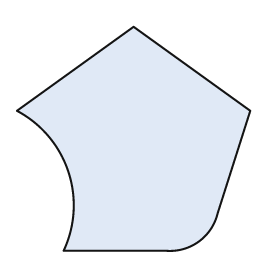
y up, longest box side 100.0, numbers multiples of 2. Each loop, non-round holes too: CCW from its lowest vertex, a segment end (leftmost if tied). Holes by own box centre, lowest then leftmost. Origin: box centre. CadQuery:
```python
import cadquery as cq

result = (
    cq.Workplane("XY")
    .moveTo(-30.0, -48.0)
    .lineTo(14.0, -48.0)
    .threePointArc((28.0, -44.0), (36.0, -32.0))
    .lineTo(50.0, 12.0)
    .lineTo(0.0, 48.0)
    .lineTo(-50.0, 12.0)
    .threePointArc((-28.0, -14.0), (-30.0, -48.0))
    .close()
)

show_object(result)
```